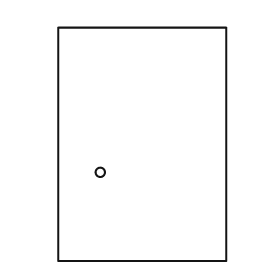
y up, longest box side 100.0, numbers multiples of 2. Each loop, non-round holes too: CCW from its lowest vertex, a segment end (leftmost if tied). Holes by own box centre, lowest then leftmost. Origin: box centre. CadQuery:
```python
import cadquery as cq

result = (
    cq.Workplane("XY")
    .moveTo(-36.0, -50.0)
    .lineTo(36.0, -50.0)
    .lineTo(36.0, 50.0)
    .lineTo(-36.0, 50.0)
    .close()
    .moveTo(-18.0, -12.0)
    .circle(2.0)
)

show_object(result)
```